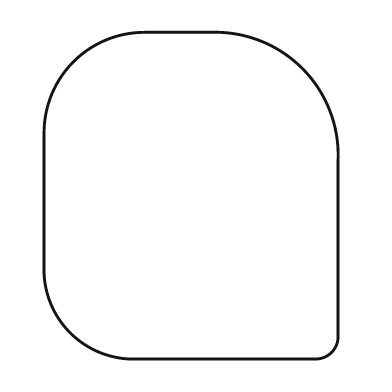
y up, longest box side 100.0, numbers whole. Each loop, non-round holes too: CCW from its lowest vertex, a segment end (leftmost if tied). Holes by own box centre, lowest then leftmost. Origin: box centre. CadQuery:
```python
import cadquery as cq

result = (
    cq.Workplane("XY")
    .moveTo(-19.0, -50.0)
    .lineTo(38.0, -50.0)
    .threePointArc((43.0, -48.0), (45.0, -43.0))
    .lineTo(45.0, 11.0)
    .threePointArc((34.0, 39.0), (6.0, 50.0))
    .lineTo(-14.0, 50.0)
    .threePointArc((-36.0, 41.0), (-45.0, 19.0))
    .lineTo(-45.0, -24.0)
    .threePointArc((-37.0, -42.0), (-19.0, -50.0))
    .close()
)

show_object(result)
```